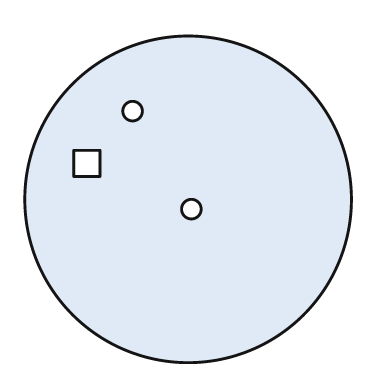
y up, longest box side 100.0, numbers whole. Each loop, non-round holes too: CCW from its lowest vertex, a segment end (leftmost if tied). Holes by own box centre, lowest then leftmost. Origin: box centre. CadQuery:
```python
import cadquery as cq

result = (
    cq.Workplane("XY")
    .moveTo(0.0, 0.0)
    .circle(50.0)
    .moveTo(1.0, -3.0)
    .circle(3.0)
    .moveTo(-35.0, 7.0)
    .lineTo(-27.0, 7.0)
    .lineTo(-27.0, 15.0)
    .lineTo(-35.0, 15.0)
    .close()
    .moveTo(-17.0, 27.0)
    .circle(3.0)
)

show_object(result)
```